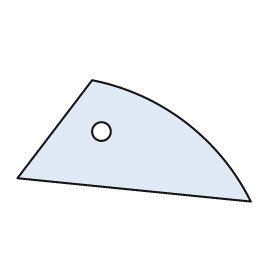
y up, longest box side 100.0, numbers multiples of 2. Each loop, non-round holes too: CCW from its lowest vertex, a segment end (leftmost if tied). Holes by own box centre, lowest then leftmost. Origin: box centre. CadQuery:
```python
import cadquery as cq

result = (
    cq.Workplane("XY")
    .moveTo(50.0, -26.0)
    .threePointArc((22.0, 8.0), (-18.0, 26.0))
    .lineTo(-50.0, -16.0)
    .close()
    .moveTo(-14.0, 4.0)
    .circle(4.0)
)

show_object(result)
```